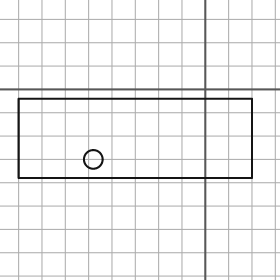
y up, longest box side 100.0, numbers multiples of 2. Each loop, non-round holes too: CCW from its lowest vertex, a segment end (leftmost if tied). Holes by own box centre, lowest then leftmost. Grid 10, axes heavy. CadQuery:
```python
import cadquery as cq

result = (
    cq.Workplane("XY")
    .moveTo(-80.0, -38.0)
    .lineTo(20.0, -38.0)
    .lineTo(20.0, -4.0)
    .lineTo(-80.0, -4.0)
    .close()
    .moveTo(-48.0, -30.0)
    .circle(4.0)
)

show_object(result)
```